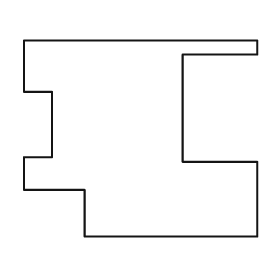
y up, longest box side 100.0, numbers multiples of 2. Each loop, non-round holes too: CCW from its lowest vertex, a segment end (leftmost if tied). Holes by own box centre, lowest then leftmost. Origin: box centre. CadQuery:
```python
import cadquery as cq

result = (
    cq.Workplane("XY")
    .moveTo(-24.0, -42.0)
    .lineTo(50.0, -42.0)
    .lineTo(50.0, -10.0)
    .lineTo(18.0, -10.0)
    .lineTo(18.0, 36.0)
    .lineTo(50.0, 36.0)
    .lineTo(50.0, 42.0)
    .lineTo(-50.0, 42.0)
    .lineTo(-50.0, 20.0)
    .lineTo(-38.0, 20.0)
    .lineTo(-38.0, -8.0)
    .lineTo(-50.0, -8.0)
    .lineTo(-50.0, -22.0)
    .lineTo(-24.0, -22.0)
    .close()
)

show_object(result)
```